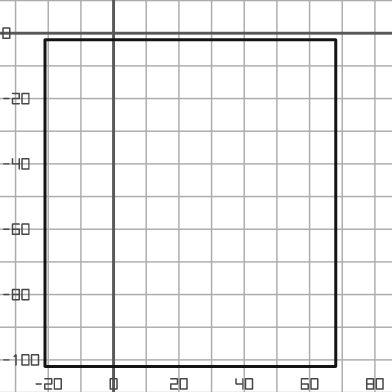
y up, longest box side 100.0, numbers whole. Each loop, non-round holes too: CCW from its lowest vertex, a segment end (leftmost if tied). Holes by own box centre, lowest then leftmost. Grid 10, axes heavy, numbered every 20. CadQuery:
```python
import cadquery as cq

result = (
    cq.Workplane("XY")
    .moveTo(-21.0, -102.0)
    .lineTo(68.0, -102.0)
    .lineTo(68.0, -2.0)
    .lineTo(-21.0, -2.0)
    .close()
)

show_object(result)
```